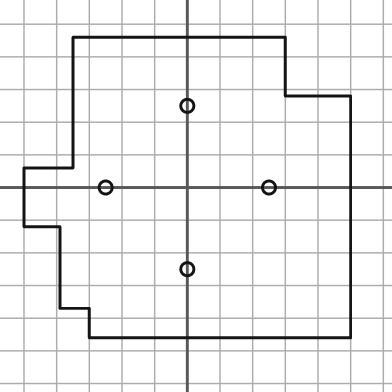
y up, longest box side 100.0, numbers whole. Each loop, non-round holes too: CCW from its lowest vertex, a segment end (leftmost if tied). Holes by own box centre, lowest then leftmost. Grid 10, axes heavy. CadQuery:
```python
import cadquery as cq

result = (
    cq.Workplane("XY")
    .moveTo(-30.0, -46.0)
    .lineTo(50.0, -46.0)
    .lineTo(50.0, 28.0)
    .lineTo(30.0, 28.0)
    .lineTo(30.0, 46.0)
    .lineTo(-35.0, 46.0)
    .lineTo(-35.0, 6.0)
    .lineTo(-50.0, 6.0)
    .lineTo(-50.0, -12.0)
    .lineTo(-39.0, -12.0)
    .lineTo(-39.0, -37.0)
    .lineTo(-30.0, -37.0)
    .close()
    .moveTo(0.0, -25.0)
    .circle(2.0)
    .moveTo(-25.0, 0.0)
    .circle(2.0)
    .moveTo(25.0, 0.0)
    .circle(2.0)
    .moveTo(0.0, 25.0)
    .circle(2.0)
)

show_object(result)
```